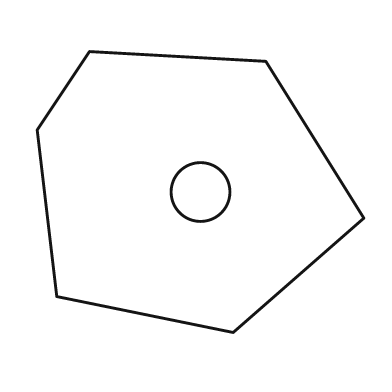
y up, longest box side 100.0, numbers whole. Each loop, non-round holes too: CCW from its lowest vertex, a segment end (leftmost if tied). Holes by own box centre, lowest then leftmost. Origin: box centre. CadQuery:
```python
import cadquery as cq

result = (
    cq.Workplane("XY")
    .moveTo(10.0, -43.0)
    .lineTo(50.0, -8.0)
    .lineTo(20.0, 40.0)
    .lineTo(-34.0, 43.0)
    .lineTo(-50.0, 19.0)
    .lineTo(-44.0, -32.0)
    .close()
    .moveTo(0.0, 0.0)
    .circle(9.0)
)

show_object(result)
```